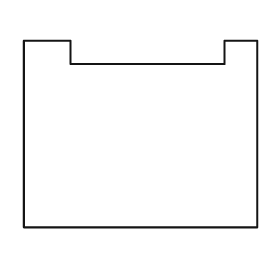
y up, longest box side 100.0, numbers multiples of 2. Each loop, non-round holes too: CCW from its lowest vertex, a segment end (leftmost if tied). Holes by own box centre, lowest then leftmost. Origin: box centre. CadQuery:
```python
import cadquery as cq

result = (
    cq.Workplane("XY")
    .moveTo(-50.0, -40.0)
    .lineTo(50.0, -40.0)
    .lineTo(50.0, 40.0)
    .lineTo(36.0, 40.0)
    .lineTo(36.0, 30.0)
    .lineTo(-30.0, 30.0)
    .lineTo(-30.0, 40.0)
    .lineTo(-50.0, 40.0)
    .close()
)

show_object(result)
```